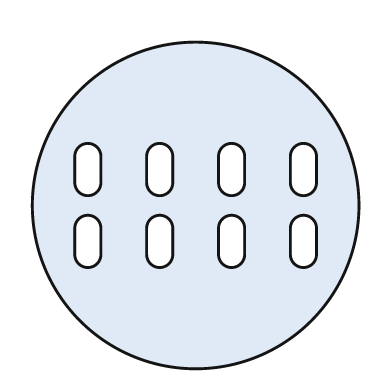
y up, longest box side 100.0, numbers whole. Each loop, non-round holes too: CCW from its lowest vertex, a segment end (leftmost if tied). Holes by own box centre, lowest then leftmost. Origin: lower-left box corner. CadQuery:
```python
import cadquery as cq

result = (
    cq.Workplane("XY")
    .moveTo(50.0, 50.0)
    .circle(50.0)
    .moveTo(13.0, 35.0)
    .threePointArc((17.0, 31.0), (21.0, 35.0))
    .lineTo(21.0, 43.0)
    .threePointArc((17.0, 47.0), (13.0, 43.0))
    .close()
    .moveTo(35.0, 35.0)
    .threePointArc((39.0, 31.0), (43.0, 35.0))
    .lineTo(43.0, 43.0)
    .threePointArc((39.0, 47.0), (35.0, 43.0))
    .close()
    .moveTo(57.0, 35.0)
    .threePointArc((61.0, 31.0), (65.0, 35.0))
    .lineTo(65.0, 43.0)
    .threePointArc((61.0, 47.0), (57.0, 43.0))
    .close()
    .moveTo(79.0, 35.0)
    .threePointArc((83.0, 31.0), (87.0, 35.0))
    .lineTo(87.0, 43.0)
    .threePointArc((83.0, 47.0), (79.0, 43.0))
    .close()
    .moveTo(13.0, 57.0)
    .threePointArc((17.0, 53.0), (21.0, 57.0))
    .lineTo(21.0, 65.0)
    .threePointArc((17.0, 69.0), (13.0, 65.0))
    .close()
    .moveTo(35.0, 57.0)
    .threePointArc((39.0, 53.0), (43.0, 57.0))
    .lineTo(43.0, 65.0)
    .threePointArc((39.0, 69.0), (35.0, 65.0))
    .close()
    .moveTo(57.0, 57.0)
    .threePointArc((61.0, 53.0), (65.0, 57.0))
    .lineTo(65.0, 65.0)
    .threePointArc((61.0, 69.0), (57.0, 65.0))
    .close()
    .moveTo(79.0, 57.0)
    .threePointArc((83.0, 53.0), (87.0, 57.0))
    .lineTo(87.0, 65.0)
    .threePointArc((83.0, 69.0), (79.0, 65.0))
    .close()
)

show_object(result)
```